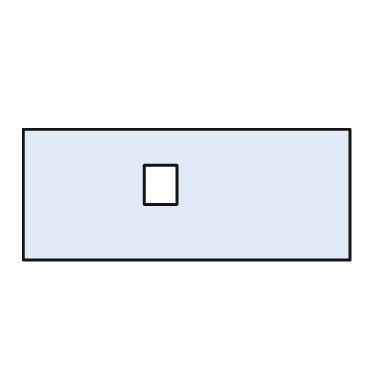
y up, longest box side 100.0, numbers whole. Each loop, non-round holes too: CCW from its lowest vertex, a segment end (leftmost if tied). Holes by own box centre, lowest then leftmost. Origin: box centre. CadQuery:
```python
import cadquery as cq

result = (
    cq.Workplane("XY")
    .moveTo(-50.0, -20.0)
    .lineTo(50.0, -20.0)
    .lineTo(50.0, 20.0)
    .lineTo(-50.0, 20.0)
    .close()
    .moveTo(-13.0, -3.0)
    .lineTo(-3.0, -3.0)
    .lineTo(-3.0, 9.0)
    .lineTo(-13.0, 9.0)
    .close()
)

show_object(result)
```